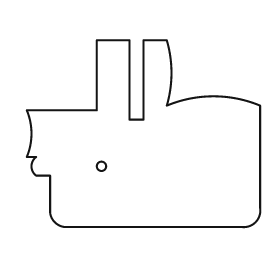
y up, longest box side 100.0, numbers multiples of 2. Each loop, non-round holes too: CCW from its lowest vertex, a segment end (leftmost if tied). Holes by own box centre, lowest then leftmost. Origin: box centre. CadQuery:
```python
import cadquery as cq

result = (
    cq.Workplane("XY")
    .moveTo(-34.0, -40.0)
    .lineTo(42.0, -40.0)
    .threePointArc((48.0, -38.0), (50.0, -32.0))
    .lineTo(50.0, 12.0)
    .threePointArc((30.0, 16.0), (10.0, 12.0))
    .threePointArc((12.0, 26.0), (10.0, 40.0))
    .lineTo(0.0, 40.0)
    .lineTo(0.0, 6.0)
    .lineTo(-6.0, 6.0)
    .lineTo(-6.0, 40.0)
    .lineTo(-20.0, 40.0)
    .lineTo(-20.0, 10.0)
    .lineTo(-50.0, 10.0)
    .threePointArc((-48.0, 0.0), (-50.0, -10.0))
    .lineTo(-46.0, -10.0)
    .threePointArc((-48.0, -14.0), (-46.0, -18.0))
    .lineTo(-40.0, -18.0)
    .lineTo(-40.0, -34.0)
    .threePointArc((-38.0, -38.0), (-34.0, -40.0))
    .close()
    .moveTo(-18.0, -14.0)
    .circle(2.0)
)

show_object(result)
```